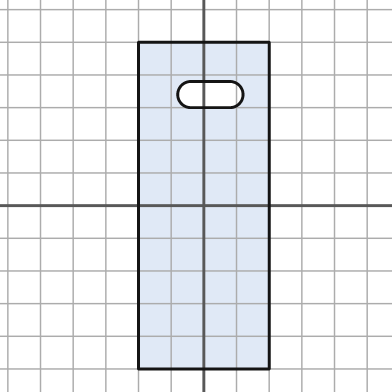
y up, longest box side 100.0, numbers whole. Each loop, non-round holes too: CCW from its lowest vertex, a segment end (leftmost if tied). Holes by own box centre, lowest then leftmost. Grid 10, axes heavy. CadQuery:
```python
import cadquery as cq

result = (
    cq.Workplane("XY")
    .moveTo(-20.0, -50.0)
    .lineTo(20.0, -50.0)
    .lineTo(20.0, 50.0)
    .lineTo(-20.0, 50.0)
    .close()
    .moveTo(-4.0, 30.0)
    .lineTo(8.0, 30.0)
    .threePointArc((12.0, 34.0), (8.0, 38.0))
    .lineTo(-4.0, 38.0)
    .threePointArc((-8.0, 34.0), (-4.0, 30.0))
    .close()
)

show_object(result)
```